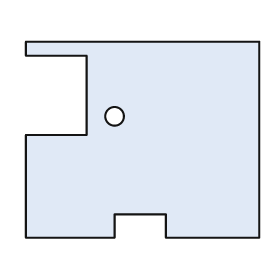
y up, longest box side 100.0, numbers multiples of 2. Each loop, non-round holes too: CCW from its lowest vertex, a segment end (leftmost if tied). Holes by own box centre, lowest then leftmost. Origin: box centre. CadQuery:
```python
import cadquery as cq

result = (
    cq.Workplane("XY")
    .moveTo(-50.0, -42.0)
    .lineTo(-12.0, -42.0)
    .lineTo(-12.0, -32.0)
    .lineTo(10.0, -32.0)
    .lineTo(10.0, -42.0)
    .lineTo(50.0, -42.0)
    .lineTo(50.0, 42.0)
    .lineTo(-50.0, 42.0)
    .lineTo(-50.0, 36.0)
    .lineTo(-24.0, 36.0)
    .lineTo(-24.0, 2.0)
    .lineTo(-50.0, 2.0)
    .close()
    .moveTo(-12.0, 10.0)
    .circle(4.0)
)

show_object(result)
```